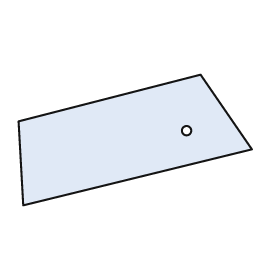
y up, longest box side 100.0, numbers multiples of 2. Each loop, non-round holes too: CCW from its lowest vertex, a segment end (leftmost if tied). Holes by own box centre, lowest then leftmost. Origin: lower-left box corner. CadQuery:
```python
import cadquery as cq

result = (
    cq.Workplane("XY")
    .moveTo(2.0, 0.0)
    .lineTo(100.0, 24.0)
    .lineTo(78.0, 56.0)
    .lineTo(0.0, 36.0)
    .close()
    .moveTo(72.0, 32.0)
    .circle(2.0)
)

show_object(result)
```